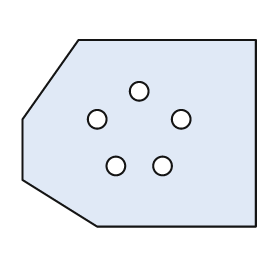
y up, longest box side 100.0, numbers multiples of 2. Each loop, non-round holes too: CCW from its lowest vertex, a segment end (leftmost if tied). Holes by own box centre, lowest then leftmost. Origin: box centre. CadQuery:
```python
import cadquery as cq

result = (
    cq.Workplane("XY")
    .moveTo(-18.0, -40.0)
    .lineTo(50.0, -40.0)
    .lineTo(50.0, 40.0)
    .lineTo(-26.0, 40.0)
    .lineTo(-50.0, 6.0)
    .lineTo(-50.0, -20.0)
    .close()
    .moveTo(-10.0, -14.0)
    .circle(4.0)
    .moveTo(10.0, -14.0)
    .circle(4.0)
    .moveTo(-18.0, 6.0)
    .circle(4.0)
    .moveTo(18.0, 6.0)
    .circle(4.0)
    .moveTo(0.0, 18.0)
    .circle(4.0)
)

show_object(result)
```